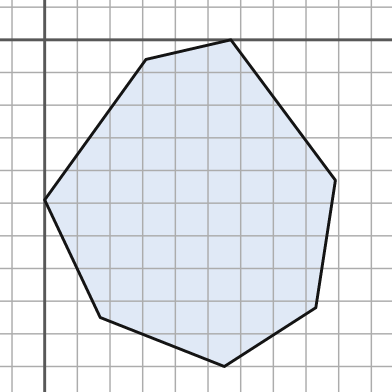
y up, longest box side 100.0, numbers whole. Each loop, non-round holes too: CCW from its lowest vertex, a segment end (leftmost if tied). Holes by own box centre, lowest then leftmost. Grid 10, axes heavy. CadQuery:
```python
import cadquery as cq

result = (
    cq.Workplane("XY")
    .moveTo(55.0, -100.0)
    .lineTo(83.0, -82.0)
    .lineTo(89.0, -43.0)
    .lineTo(57.0, 0.0)
    .lineTo(31.0, -6.0)
    .lineTo(0.0, -49.0)
    .lineTo(17.0, -85.0)
    .close()
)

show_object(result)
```